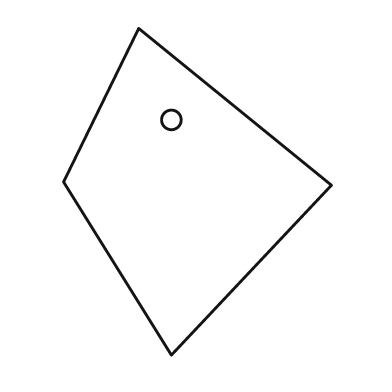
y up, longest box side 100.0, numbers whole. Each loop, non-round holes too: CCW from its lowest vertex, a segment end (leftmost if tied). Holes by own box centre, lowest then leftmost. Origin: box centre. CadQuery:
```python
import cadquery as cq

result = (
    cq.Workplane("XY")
    .moveTo(-8.0, -50.0)
    .lineTo(41.0, 2.0)
    .lineTo(-18.0, 50.0)
    .lineTo(-41.0, 3.0)
    .close()
    .moveTo(-8.0, 22.0)
    .circle(3.0)
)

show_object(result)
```